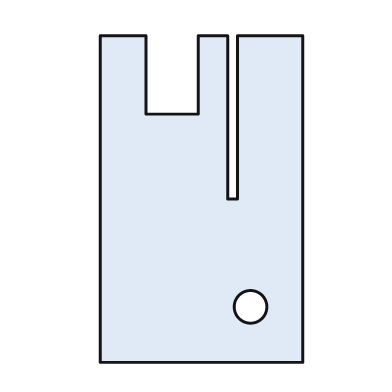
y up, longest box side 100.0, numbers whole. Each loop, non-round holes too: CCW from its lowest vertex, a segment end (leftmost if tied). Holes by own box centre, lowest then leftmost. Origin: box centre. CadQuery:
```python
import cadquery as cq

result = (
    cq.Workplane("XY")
    .moveTo(-31.0, -50.0)
    .lineTo(31.0, -50.0)
    .lineTo(31.0, 50.0)
    .lineTo(11.0, 50.0)
    .lineTo(11.0, 0.0)
    .lineTo(8.0, 0.0)
    .lineTo(8.0, 50.0)
    .lineTo(-1.0, 50.0)
    .lineTo(-1.0, 26.0)
    .lineTo(-17.0, 26.0)
    .lineTo(-17.0, 50.0)
    .lineTo(-31.0, 50.0)
    .close()
    .moveTo(15.0, -33.0)
    .circle(5.0)
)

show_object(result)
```